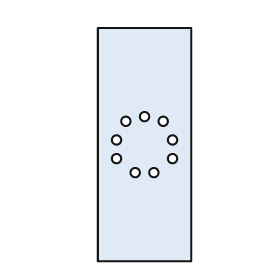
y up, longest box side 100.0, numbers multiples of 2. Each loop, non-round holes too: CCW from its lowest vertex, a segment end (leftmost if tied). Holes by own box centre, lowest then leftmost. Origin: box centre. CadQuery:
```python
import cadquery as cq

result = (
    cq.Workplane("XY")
    .moveTo(-20.0, -50.0)
    .lineTo(20.0, -50.0)
    .lineTo(20.0, 50.0)
    .lineTo(-20.0, 50.0)
    .close()
    .moveTo(-4.0, -12.0)
    .circle(2.0)
    .moveTo(4.0, -12.0)
    .circle(2.0)
    .moveTo(-12.0, -6.0)
    .circle(2.0)
    .moveTo(12.0, -6.0)
    .circle(2.0)
    .moveTo(-12.0, 2.0)
    .circle(2.0)
    .moveTo(12.0, 2.0)
    .circle(2.0)
    .moveTo(-8.0, 10.0)
    .circle(2.0)
    .moveTo(8.0, 10.0)
    .circle(2.0)
    .moveTo(0.0, 12.0)
    .circle(2.0)
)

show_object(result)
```